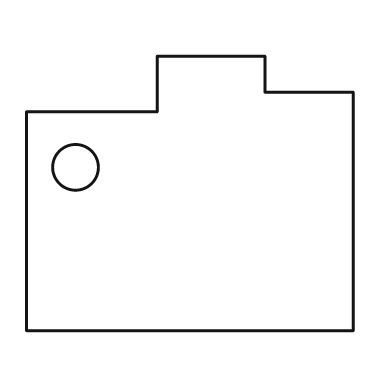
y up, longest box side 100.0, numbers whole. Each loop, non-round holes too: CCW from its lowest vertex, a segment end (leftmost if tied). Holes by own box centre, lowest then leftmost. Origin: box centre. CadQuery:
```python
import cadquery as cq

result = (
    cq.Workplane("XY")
    .moveTo(-50.0, -42.0)
    .lineTo(50.0, -42.0)
    .lineTo(50.0, 31.0)
    .lineTo(23.0, 31.0)
    .lineTo(23.0, 42.0)
    .lineTo(-10.0, 42.0)
    .lineTo(-10.0, 25.0)
    .lineTo(-50.0, 25.0)
    .close()
    .moveTo(-35.0, 8.0)
    .circle(7.0)
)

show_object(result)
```